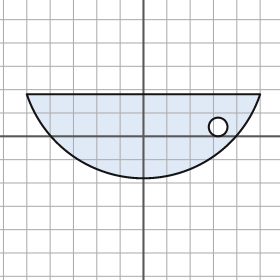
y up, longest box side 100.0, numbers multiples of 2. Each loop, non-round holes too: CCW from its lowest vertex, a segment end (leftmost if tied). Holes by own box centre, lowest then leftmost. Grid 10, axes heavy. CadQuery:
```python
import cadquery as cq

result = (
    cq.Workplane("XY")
    .moveTo(-50.0, 18.0)
    .threePointArc((0.0, -18.0), (50.0, 18.0))
    .close()
    .moveTo(32.0, 4.0)
    .circle(4.0)
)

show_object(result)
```